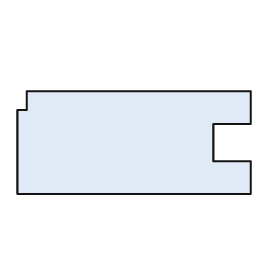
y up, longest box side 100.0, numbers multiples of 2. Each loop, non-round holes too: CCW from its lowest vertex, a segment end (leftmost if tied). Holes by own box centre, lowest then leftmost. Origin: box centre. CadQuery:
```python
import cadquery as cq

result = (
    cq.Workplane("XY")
    .moveTo(-50.0, -22.0)
    .lineTo(50.0, -22.0)
    .lineTo(50.0, -8.0)
    .lineTo(34.0, -8.0)
    .lineTo(34.0, 8.0)
    .lineTo(50.0, 8.0)
    .lineTo(50.0, 22.0)
    .lineTo(-46.0, 22.0)
    .lineTo(-46.0, 14.0)
    .lineTo(-50.0, 14.0)
    .close()
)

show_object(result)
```